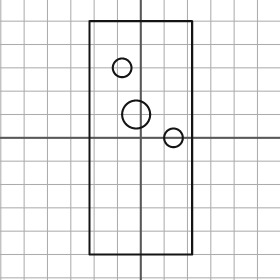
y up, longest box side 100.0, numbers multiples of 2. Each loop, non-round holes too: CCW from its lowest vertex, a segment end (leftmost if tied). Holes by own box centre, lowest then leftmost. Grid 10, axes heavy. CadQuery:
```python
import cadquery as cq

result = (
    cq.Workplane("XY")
    .moveTo(-22.0, -50.0)
    .lineTo(22.0, -50.0)
    .lineTo(22.0, 50.0)
    .lineTo(-22.0, 50.0)
    .close()
    .moveTo(14.0, 0.0)
    .circle(4.0)
    .moveTo(-2.0, 10.0)
    .circle(6.0)
    .moveTo(-8.0, 30.0)
    .circle(4.0)
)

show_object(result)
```